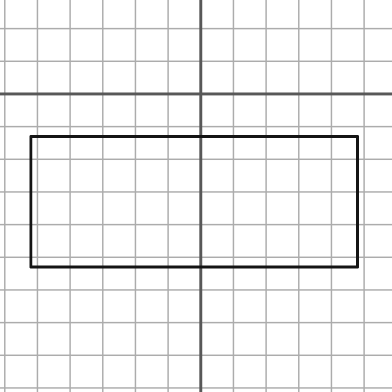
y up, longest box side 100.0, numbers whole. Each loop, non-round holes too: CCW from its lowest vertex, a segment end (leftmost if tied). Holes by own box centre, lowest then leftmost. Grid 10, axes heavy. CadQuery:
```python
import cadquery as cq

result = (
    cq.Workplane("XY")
    .moveTo(-52.0, -53.0)
    .lineTo(48.0, -53.0)
    .lineTo(48.0, -13.0)
    .lineTo(-52.0, -13.0)
    .close()
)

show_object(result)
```